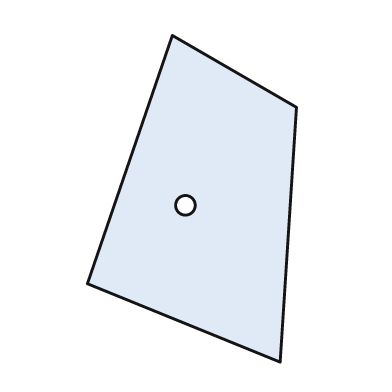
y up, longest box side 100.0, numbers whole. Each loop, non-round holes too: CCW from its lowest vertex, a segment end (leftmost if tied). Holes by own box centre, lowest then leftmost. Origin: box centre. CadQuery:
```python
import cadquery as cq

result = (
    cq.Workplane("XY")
    .moveTo(27.0, -50.0)
    .lineTo(32.0, 28.0)
    .lineTo(-6.0, 50.0)
    .lineTo(-32.0, -26.0)
    .close()
    .moveTo(-2.0, -2.0)
    .circle(3.0)
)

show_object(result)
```